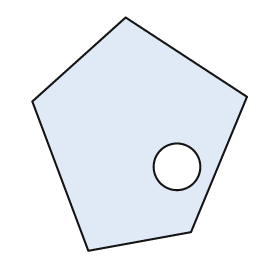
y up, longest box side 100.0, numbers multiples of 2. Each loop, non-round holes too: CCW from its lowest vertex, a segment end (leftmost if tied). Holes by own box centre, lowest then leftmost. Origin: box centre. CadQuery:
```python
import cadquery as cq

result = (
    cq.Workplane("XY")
    .moveTo(-22.0, -50.0)
    .lineTo(22.0, -42.0)
    .lineTo(46.0, 16.0)
    .lineTo(-6.0, 50.0)
    .lineTo(-46.0, 14.0)
    .close()
    .moveTo(16.0, -14.0)
    .circle(10.0)
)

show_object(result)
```